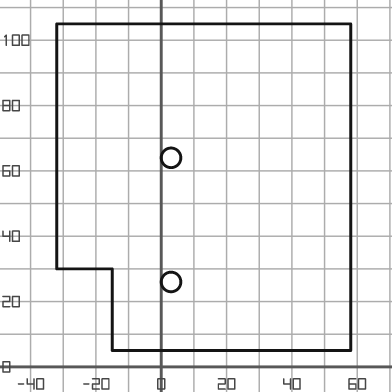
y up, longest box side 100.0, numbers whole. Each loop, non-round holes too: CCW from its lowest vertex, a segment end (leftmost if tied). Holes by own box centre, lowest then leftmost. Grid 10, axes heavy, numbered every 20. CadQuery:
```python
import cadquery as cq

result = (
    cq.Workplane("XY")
    .moveTo(-15.0, 5.0)
    .lineTo(58.0, 5.0)
    .lineTo(58.0, 105.0)
    .lineTo(-32.0, 105.0)
    .lineTo(-32.0, 30.0)
    .lineTo(-15.0, 30.0)
    .close()
    .moveTo(3.0, 26.0)
    .circle(3.0)
    .moveTo(3.0, 64.0)
    .circle(3.0)
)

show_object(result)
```